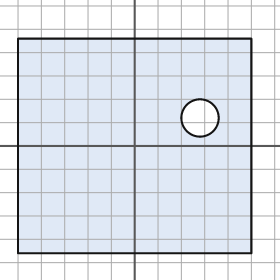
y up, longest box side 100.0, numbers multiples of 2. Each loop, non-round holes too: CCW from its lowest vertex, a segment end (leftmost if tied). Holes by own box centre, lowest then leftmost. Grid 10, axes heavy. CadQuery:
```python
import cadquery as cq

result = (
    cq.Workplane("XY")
    .moveTo(-50.0, -46.0)
    .lineTo(50.0, -46.0)
    .lineTo(50.0, 46.0)
    .lineTo(-50.0, 46.0)
    .close()
    .moveTo(28.0, 12.0)
    .circle(8.0)
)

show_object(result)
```